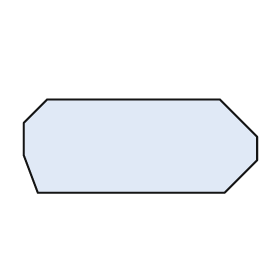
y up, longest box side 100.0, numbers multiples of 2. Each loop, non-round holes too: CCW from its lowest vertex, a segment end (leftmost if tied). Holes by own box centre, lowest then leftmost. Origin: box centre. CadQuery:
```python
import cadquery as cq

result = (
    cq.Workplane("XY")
    .moveTo(-44.0, -20.0)
    .lineTo(36.0, -20.0)
    .lineTo(50.0, -6.0)
    .lineTo(50.0, 4.0)
    .lineTo(34.0, 20.0)
    .lineTo(-40.0, 20.0)
    .lineTo(-50.0, 10.0)
    .lineTo(-50.0, -4.0)
    .close()
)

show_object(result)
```